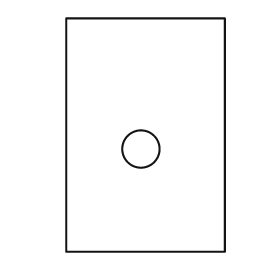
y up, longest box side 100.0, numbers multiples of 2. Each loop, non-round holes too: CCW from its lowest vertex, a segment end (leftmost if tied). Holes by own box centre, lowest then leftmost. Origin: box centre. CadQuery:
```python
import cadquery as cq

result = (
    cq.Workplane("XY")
    .moveTo(-34.0, -50.0)
    .lineTo(34.0, -50.0)
    .lineTo(34.0, 50.0)
    .lineTo(-34.0, 50.0)
    .close()
    .moveTo(-2.0, -6.0)
    .circle(8.0)
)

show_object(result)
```